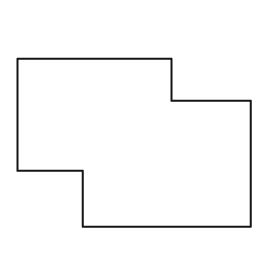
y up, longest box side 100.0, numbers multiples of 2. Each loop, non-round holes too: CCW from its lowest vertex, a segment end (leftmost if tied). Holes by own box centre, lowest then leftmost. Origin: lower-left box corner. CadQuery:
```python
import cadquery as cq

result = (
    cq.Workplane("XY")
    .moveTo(28.0, 0.0)
    .lineTo(100.0, 0.0)
    .lineTo(100.0, 54.0)
    .lineTo(66.0, 54.0)
    .lineTo(66.0, 72.0)
    .lineTo(0.0, 72.0)
    .lineTo(0.0, 24.0)
    .lineTo(28.0, 24.0)
    .close()
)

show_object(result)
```